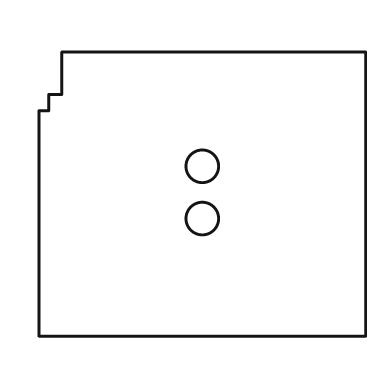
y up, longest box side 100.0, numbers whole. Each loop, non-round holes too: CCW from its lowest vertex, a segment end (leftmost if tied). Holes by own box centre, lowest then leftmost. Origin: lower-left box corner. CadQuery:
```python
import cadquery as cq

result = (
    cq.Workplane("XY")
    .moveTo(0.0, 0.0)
    .lineTo(100.0, 0.0)
    .lineTo(100.0, 87.0)
    .lineTo(7.0, 87.0)
    .lineTo(7.0, 74.0)
    .lineTo(3.0, 74.0)
    .lineTo(3.0, 69.0)
    .lineTo(0.0, 69.0)
    .close()
    .moveTo(50.0, 36.0)
    .circle(5.0)
    .moveTo(50.0, 52.0)
    .circle(5.0)
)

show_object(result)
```